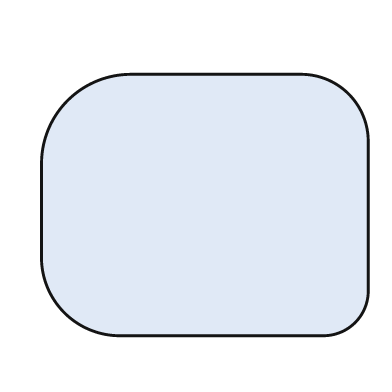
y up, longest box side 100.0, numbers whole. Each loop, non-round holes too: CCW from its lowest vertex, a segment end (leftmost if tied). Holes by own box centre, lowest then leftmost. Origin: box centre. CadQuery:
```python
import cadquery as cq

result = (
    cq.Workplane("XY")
    .moveTo(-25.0, -40.0)
    .lineTo(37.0, -40.0)
    .threePointArc((46.0, -36.0), (50.0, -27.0))
    .lineTo(50.0, 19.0)
    .threePointArc((44.0, 34.0), (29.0, 40.0))
    .lineTo(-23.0, 40.0)
    .threePointArc((-42.0, 32.0), (-50.0, 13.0))
    .lineTo(-50.0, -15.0)
    .threePointArc((-43.0, -33.0), (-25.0, -40.0))
    .close()
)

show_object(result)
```